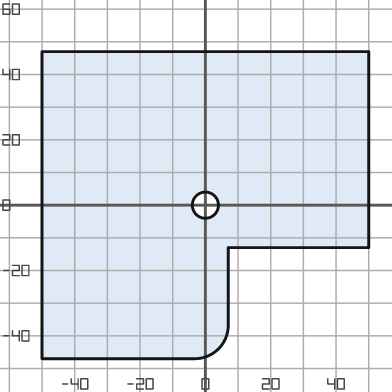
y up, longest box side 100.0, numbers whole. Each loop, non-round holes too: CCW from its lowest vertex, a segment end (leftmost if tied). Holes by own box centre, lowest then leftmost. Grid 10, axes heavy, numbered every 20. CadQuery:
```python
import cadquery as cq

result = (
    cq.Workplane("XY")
    .moveTo(-50.0, -47.0)
    .lineTo(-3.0, -47.0)
    .threePointArc((4.0, -44.0), (7.0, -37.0))
    .lineTo(7.0, -13.0)
    .lineTo(50.0, -13.0)
    .lineTo(50.0, 47.0)
    .lineTo(-50.0, 47.0)
    .close()
    .moveTo(0.0, 0.0)
    .circle(4.0)
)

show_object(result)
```